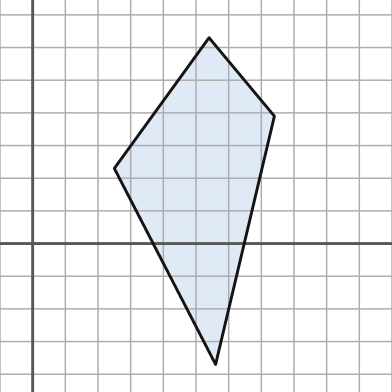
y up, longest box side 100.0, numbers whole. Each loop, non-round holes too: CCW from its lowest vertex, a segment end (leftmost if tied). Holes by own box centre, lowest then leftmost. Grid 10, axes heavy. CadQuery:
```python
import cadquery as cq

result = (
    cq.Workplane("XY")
    .moveTo(56.0, -37.0)
    .lineTo(74.0, 39.0)
    .lineTo(54.0, 63.0)
    .lineTo(25.0, 23.0)
    .close()
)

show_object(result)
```